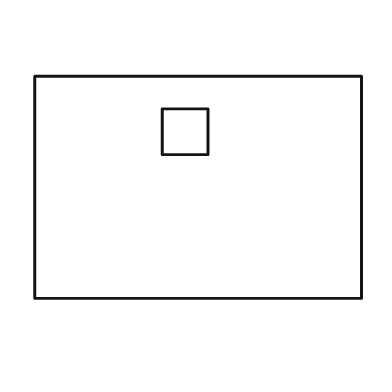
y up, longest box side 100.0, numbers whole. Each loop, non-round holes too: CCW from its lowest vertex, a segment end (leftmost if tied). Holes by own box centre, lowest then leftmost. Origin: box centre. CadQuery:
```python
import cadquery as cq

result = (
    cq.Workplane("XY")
    .moveTo(-50.0, -34.0)
    .lineTo(50.0, -34.0)
    .lineTo(50.0, 34.0)
    .lineTo(-50.0, 34.0)
    .close()
    .moveTo(-11.0, 10.0)
    .lineTo(3.0, 10.0)
    .lineTo(3.0, 24.0)
    .lineTo(-11.0, 24.0)
    .close()
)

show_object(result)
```